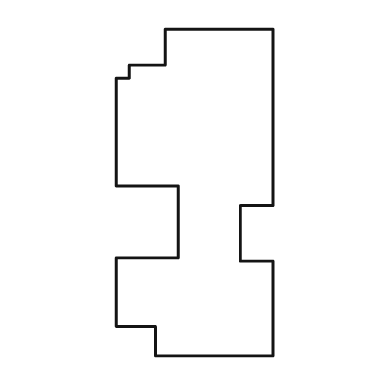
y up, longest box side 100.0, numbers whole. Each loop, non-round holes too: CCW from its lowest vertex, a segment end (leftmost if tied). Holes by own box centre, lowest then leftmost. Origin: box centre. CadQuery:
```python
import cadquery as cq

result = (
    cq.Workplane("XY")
    .moveTo(-12.0, -50.0)
    .lineTo(24.0, -50.0)
    .lineTo(24.0, -21.0)
    .lineTo(14.0, -21.0)
    .lineTo(14.0, -4.0)
    .lineTo(24.0, -4.0)
    .lineTo(24.0, 50.0)
    .lineTo(-9.0, 50.0)
    .lineTo(-9.0, 39.0)
    .lineTo(-20.0, 39.0)
    .lineTo(-20.0, 35.0)
    .lineTo(-24.0, 35.0)
    .lineTo(-24.0, 2.0)
    .lineTo(-5.0, 2.0)
    .lineTo(-5.0, -20.0)
    .lineTo(-24.0, -20.0)
    .lineTo(-24.0, -41.0)
    .lineTo(-12.0, -41.0)
    .close()
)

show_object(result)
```